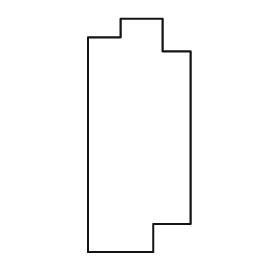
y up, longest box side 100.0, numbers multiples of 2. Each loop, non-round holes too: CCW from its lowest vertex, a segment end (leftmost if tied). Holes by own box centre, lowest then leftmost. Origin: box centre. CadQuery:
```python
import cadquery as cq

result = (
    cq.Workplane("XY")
    .moveTo(-22.0, -50.0)
    .lineTo(6.0, -50.0)
    .lineTo(6.0, -38.0)
    .lineTo(22.0, -38.0)
    .lineTo(22.0, 36.0)
    .lineTo(10.0, 36.0)
    .lineTo(10.0, 50.0)
    .lineTo(-8.0, 50.0)
    .lineTo(-8.0, 42.0)
    .lineTo(-22.0, 42.0)
    .close()
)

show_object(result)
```